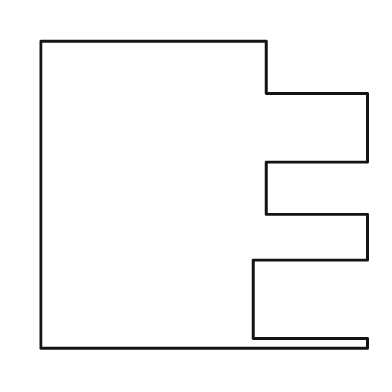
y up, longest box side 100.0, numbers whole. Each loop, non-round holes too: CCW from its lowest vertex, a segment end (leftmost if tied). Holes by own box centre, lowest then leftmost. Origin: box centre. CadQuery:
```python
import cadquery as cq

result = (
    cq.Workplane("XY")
    .moveTo(-50.0, -47.0)
    .lineTo(50.0, -47.0)
    .lineTo(50.0, -44.0)
    .lineTo(15.0, -44.0)
    .lineTo(15.0, -20.0)
    .lineTo(50.0, -20.0)
    .lineTo(50.0, -6.0)
    .lineTo(19.0, -6.0)
    .lineTo(19.0, 10.0)
    .lineTo(50.0, 10.0)
    .lineTo(50.0, 31.0)
    .lineTo(19.0, 31.0)
    .lineTo(19.0, 47.0)
    .lineTo(-50.0, 47.0)
    .close()
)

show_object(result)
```